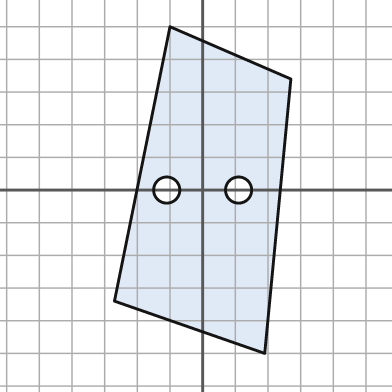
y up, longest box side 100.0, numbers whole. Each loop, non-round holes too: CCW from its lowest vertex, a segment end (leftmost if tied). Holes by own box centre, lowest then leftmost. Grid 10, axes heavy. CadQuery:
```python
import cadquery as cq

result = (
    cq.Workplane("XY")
    .moveTo(19.0, -50.0)
    .lineTo(27.0, 34.0)
    .lineTo(-10.0, 50.0)
    .lineTo(-27.0, -34.0)
    .close()
    .moveTo(-11.0, 0.0)
    .circle(4.0)
    .moveTo(11.0, 0.0)
    .circle(4.0)
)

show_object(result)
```